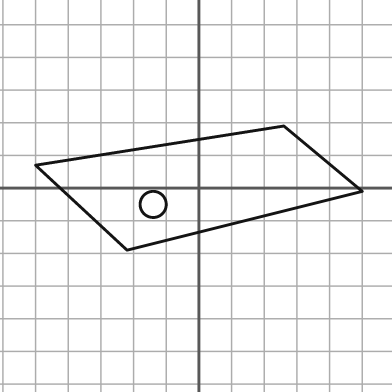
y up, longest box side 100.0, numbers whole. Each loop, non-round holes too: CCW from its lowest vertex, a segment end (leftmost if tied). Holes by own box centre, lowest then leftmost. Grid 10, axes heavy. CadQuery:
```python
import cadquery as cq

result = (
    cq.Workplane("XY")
    .moveTo(-22.0, -19.0)
    .lineTo(50.0, -1.0)
    .lineTo(26.0, 19.0)
    .lineTo(-50.0, 7.0)
    .close()
    .moveTo(-14.0, -5.0)
    .circle(4.0)
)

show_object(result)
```